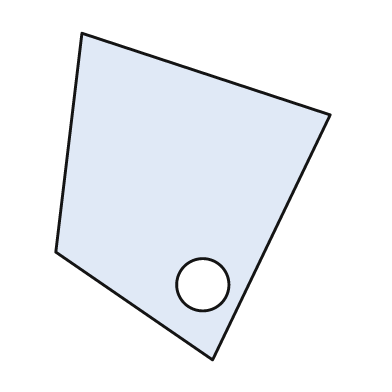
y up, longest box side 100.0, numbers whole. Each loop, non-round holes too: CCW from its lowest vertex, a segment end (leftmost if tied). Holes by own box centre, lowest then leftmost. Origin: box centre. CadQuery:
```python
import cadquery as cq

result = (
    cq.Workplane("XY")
    .moveTo(6.0, -50.0)
    .lineTo(42.0, 25.0)
    .lineTo(-34.0, 50.0)
    .lineTo(-42.0, -17.0)
    .close()
    .moveTo(3.0, -27.0)
    .circle(8.0)
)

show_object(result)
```